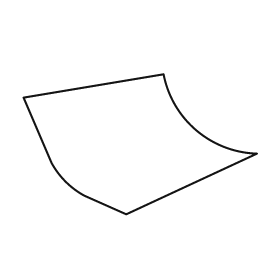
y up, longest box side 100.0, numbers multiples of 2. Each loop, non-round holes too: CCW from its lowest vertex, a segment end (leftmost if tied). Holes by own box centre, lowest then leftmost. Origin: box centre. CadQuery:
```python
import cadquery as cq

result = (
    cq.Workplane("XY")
    .moveTo(-6.0, -30.0)
    .lineTo(50.0, -4.0)
    .threePointArc((24.0, 6.0), (10.0, 30.0))
    .lineTo(-50.0, 20.0)
    .lineTo(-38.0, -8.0)
    .threePointArc((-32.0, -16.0), (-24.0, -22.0))
    .close()
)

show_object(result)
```